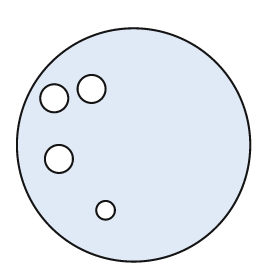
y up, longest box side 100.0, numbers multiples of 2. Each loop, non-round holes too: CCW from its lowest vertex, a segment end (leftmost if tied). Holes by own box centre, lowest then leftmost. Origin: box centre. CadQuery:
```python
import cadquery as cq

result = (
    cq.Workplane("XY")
    .moveTo(0.0, 0.0)
    .circle(50.0)
    .moveTo(-12.0, -28.0)
    .circle(4.0)
    .moveTo(-32.0, -6.0)
    .circle(6.0)
    .moveTo(-34.0, 20.0)
    .circle(6.0)
    .moveTo(-18.0, 24.0)
    .circle(6.0)
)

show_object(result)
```